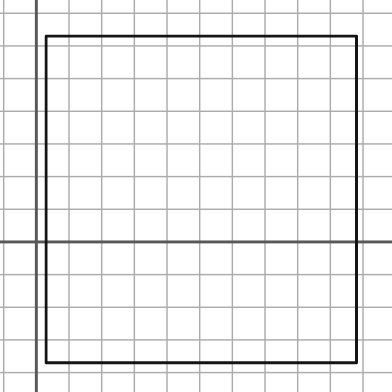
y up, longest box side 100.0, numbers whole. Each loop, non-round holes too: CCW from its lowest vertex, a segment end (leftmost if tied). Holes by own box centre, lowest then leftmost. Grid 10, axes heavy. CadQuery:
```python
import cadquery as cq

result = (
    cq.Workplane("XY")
    .moveTo(3.0, -37.0)
    .lineTo(98.0, -37.0)
    .lineTo(98.0, 63.0)
    .lineTo(3.0, 63.0)
    .close()
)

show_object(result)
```